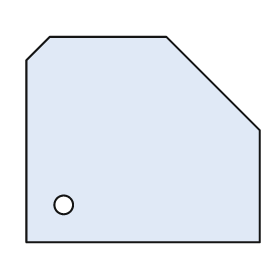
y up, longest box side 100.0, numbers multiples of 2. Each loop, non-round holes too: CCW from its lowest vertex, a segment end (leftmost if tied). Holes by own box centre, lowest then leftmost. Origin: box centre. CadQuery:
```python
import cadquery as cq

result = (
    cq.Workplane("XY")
    .moveTo(-50.0, -44.0)
    .lineTo(50.0, -44.0)
    .lineTo(50.0, 4.0)
    .lineTo(10.0, 44.0)
    .lineTo(-40.0, 44.0)
    .lineTo(-50.0, 34.0)
    .close()
    .moveTo(-34.0, -28.0)
    .circle(4.0)
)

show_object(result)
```